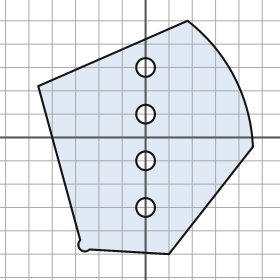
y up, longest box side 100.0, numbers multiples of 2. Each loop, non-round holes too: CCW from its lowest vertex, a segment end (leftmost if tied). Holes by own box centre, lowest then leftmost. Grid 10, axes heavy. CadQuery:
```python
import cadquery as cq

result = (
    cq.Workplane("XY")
    .moveTo(10.0, -50.0)
    .lineTo(46.0, -4.0)
    .threePointArc((38.0, 26.0), (18.0, 50.0))
    .lineTo(-46.0, 22.0)
    .lineTo(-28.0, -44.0)
    .threePointArc((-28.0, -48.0), (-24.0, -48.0))
    .close()
    .moveTo(0.0, -30.0)
    .circle(4.0)
    .moveTo(0.0, -10.0)
    .circle(4.0)
    .moveTo(0.0, 10.0)
    .circle(4.0)
    .moveTo(0.0, 30.0)
    .circle(4.0)
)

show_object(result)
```